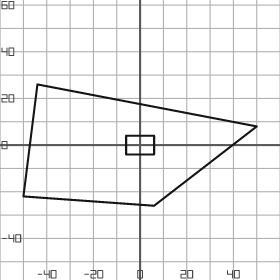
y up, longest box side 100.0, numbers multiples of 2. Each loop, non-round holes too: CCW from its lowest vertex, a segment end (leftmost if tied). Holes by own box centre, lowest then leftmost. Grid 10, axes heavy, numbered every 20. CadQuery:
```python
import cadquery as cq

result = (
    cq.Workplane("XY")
    .moveTo(6.0, -26.0)
    .lineTo(50.0, 8.0)
    .lineTo(-44.0, 26.0)
    .lineTo(-50.0, -22.0)
    .close()
    .moveTo(-6.0, -4.0)
    .lineTo(6.0, -4.0)
    .lineTo(6.0, 4.0)
    .lineTo(-6.0, 4.0)
    .close()
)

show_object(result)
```